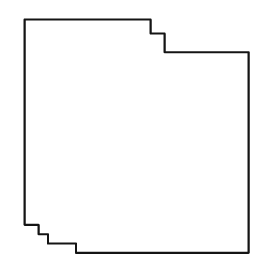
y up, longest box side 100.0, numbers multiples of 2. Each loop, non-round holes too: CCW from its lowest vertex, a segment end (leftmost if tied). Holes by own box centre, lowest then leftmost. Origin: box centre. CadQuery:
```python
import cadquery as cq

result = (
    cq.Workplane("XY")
    .moveTo(-26.0, -50.0)
    .lineTo(48.0, -50.0)
    .lineTo(48.0, 36.0)
    .lineTo(12.0, 36.0)
    .lineTo(12.0, 44.0)
    .lineTo(6.0, 44.0)
    .lineTo(6.0, 50.0)
    .lineTo(-48.0, 50.0)
    .lineTo(-48.0, -38.0)
    .lineTo(-42.0, -38.0)
    .lineTo(-42.0, -42.0)
    .lineTo(-38.0, -42.0)
    .lineTo(-38.0, -46.0)
    .lineTo(-26.0, -46.0)
    .close()
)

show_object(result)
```